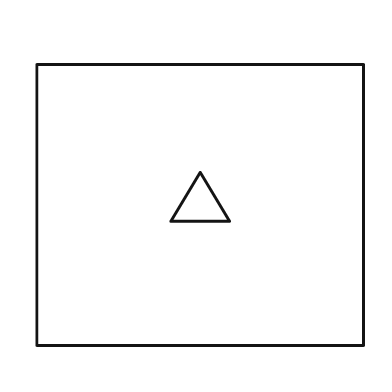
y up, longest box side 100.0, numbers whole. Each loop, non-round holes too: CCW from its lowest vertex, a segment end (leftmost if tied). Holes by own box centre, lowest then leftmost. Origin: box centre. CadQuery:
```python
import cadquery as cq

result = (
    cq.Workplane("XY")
    .moveTo(-50.0, -43.0)
    .lineTo(50.0, -43.0)
    .lineTo(50.0, 43.0)
    .lineTo(-50.0, 43.0)
    .close()
    .moveTo(-9.0, -5.0)
    .lineTo(9.0, -5.0)
    .lineTo(0.0, 10.0)
    .close()
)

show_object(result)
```